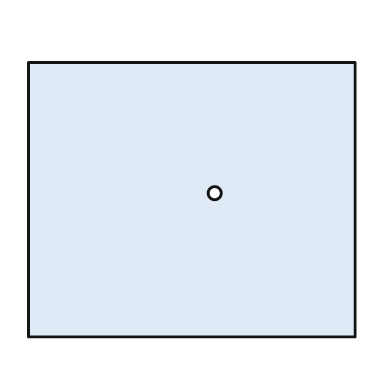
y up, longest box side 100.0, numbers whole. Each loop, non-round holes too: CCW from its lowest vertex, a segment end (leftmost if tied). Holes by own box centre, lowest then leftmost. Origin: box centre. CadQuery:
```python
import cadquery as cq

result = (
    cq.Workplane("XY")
    .moveTo(-50.0, -42.0)
    .lineTo(50.0, -42.0)
    .lineTo(50.0, 42.0)
    .lineTo(-50.0, 42.0)
    .close()
    .moveTo(7.0, 2.0)
    .circle(2.0)
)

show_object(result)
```